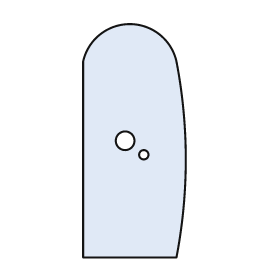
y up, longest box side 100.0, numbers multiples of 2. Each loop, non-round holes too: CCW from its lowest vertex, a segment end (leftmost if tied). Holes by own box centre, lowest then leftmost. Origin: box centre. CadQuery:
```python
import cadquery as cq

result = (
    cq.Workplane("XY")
    .moveTo(-22.0, -50.0)
    .lineTo(18.0, -50.0)
    .threePointArc((22.0, -8.0), (18.0, 34.0))
    .threePointArc((-2.0, 50.0), (-22.0, 34.0))
    .close()
    .moveTo(4.0, -6.0)
    .circle(2.0)
    .moveTo(-4.0, 0.0)
    .circle(4.0)
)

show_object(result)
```